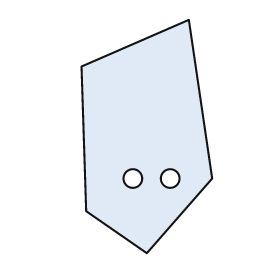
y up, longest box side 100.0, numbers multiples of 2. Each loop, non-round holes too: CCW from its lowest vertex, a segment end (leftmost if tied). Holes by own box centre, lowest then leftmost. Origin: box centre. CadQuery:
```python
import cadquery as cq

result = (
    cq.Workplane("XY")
    .moveTo(0.0, -50.0)
    .lineTo(28.0, -18.0)
    .lineTo(18.0, 50.0)
    .lineTo(-28.0, 30.0)
    .lineTo(-26.0, -32.0)
    .close()
    .moveTo(-6.0, -18.0)
    .circle(4.0)
    .moveTo(10.0, -18.0)
    .circle(4.0)
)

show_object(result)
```